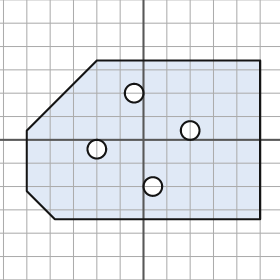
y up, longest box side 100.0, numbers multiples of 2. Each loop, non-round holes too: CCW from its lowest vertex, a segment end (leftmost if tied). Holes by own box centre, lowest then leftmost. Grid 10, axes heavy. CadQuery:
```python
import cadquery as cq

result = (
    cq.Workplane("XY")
    .moveTo(-38.0, -34.0)
    .lineTo(50.0, -34.0)
    .lineTo(50.0, 34.0)
    .lineTo(-20.0, 34.0)
    .lineTo(-50.0, 4.0)
    .lineTo(-50.0, -22.0)
    .close()
    .moveTo(4.0, -20.0)
    .circle(4.0)
    .moveTo(-20.0, -4.0)
    .circle(4.0)
    .moveTo(20.0, 4.0)
    .circle(4.0)
    .moveTo(-4.0, 20.0)
    .circle(4.0)
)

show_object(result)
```